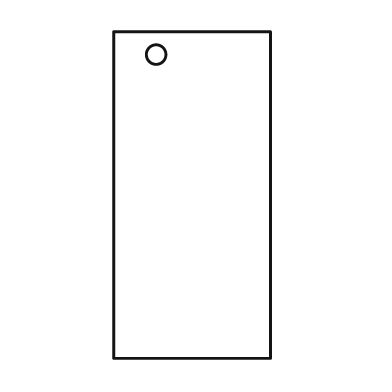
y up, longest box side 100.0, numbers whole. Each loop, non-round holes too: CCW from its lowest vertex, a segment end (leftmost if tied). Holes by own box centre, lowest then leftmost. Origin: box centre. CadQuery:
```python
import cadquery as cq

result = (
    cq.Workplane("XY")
    .moveTo(-24.0, -50.0)
    .lineTo(24.0, -50.0)
    .lineTo(24.0, 50.0)
    .lineTo(-24.0, 50.0)
    .close()
    .moveTo(-11.0, 43.0)
    .circle(3.0)
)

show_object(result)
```